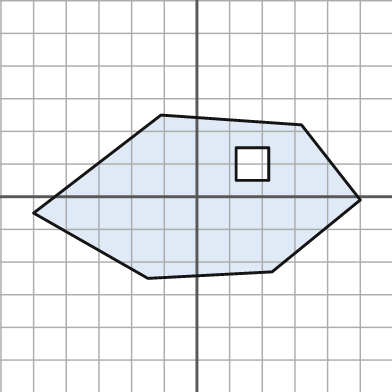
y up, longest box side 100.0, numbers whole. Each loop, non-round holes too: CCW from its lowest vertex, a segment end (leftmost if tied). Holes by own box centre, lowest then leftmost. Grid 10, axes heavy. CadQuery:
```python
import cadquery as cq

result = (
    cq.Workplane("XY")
    .moveTo(-15.0, -25.0)
    .lineTo(23.0, -23.0)
    .lineTo(50.0, -1.0)
    .lineTo(32.0, 22.0)
    .lineTo(-11.0, 25.0)
    .lineTo(-50.0, -5.0)
    .close()
    .moveTo(12.0, 5.0)
    .lineTo(22.0, 5.0)
    .lineTo(22.0, 15.0)
    .lineTo(12.0, 15.0)
    .close()
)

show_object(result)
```